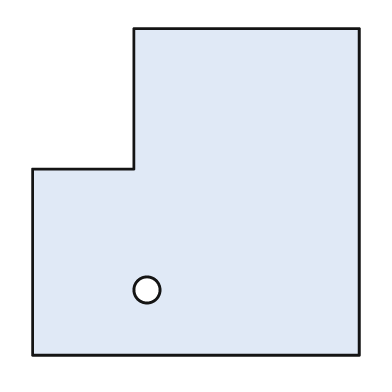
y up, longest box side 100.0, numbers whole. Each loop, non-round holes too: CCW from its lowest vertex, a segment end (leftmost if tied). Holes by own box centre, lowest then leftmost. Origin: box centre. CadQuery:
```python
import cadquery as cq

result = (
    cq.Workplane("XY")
    .moveTo(-50.0, -50.0)
    .lineTo(50.0, -50.0)
    .lineTo(50.0, 50.0)
    .lineTo(-19.0, 50.0)
    .lineTo(-19.0, 7.0)
    .lineTo(-50.0, 7.0)
    .close()
    .moveTo(-15.0, -30.0)
    .circle(4.0)
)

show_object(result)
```